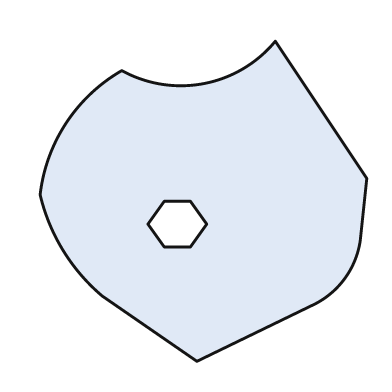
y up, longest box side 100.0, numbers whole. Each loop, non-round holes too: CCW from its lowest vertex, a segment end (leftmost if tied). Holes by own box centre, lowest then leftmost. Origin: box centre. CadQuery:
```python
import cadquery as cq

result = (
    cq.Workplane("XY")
    .moveTo(-2.0, -49.0)
    .lineTo(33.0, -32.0)
    .threePointArc((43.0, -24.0), (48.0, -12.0))
    .lineTo(50.0, 7.0)
    .lineTo(22.0, 49.0)
    .threePointArc((0.0, 36.0), (-25.0, 40.0))
    .threePointArc((-42.0, 24.0), (-50.0, 2.0))
    .threePointArc((-43.0, -15.0), (-31.0, -29.0))
    .close()
    .moveTo(-12.0, -14.0)
    .lineTo(-4.0, -14.0)
    .lineTo(1.0, -7.0)
    .lineTo(-4.0, 0.0)
    .lineTo(-12.0, 0.0)
    .lineTo(-17.0, -7.0)
    .close()
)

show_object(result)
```